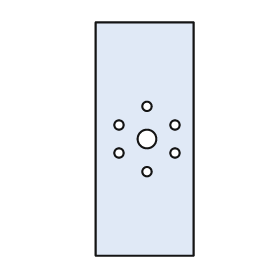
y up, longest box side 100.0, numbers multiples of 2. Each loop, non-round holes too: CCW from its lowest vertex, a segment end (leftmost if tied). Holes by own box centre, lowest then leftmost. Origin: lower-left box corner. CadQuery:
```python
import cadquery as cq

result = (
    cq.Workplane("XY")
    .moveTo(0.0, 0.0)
    .lineTo(42.0, 0.0)
    .lineTo(42.0, 100.0)
    .lineTo(0.0, 100.0)
    .close()
    .moveTo(22.0, 36.0)
    .circle(2.0)
    .moveTo(10.0, 44.0)
    .circle(2.0)
    .moveTo(34.0, 44.0)
    .circle(2.0)
    .moveTo(22.0, 50.0)
    .circle(4.0)
    .moveTo(10.0, 56.0)
    .circle(2.0)
    .moveTo(34.0, 56.0)
    .circle(2.0)
    .moveTo(22.0, 64.0)
    .circle(2.0)
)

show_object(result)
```